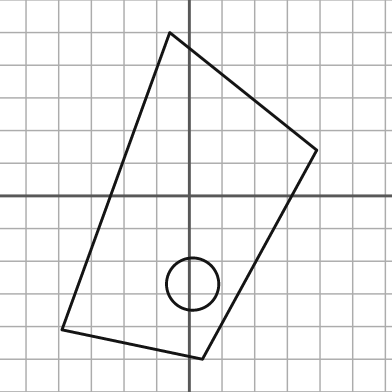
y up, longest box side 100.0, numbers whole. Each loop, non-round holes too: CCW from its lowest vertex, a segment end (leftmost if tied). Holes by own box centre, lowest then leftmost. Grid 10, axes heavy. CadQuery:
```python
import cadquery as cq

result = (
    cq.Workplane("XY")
    .moveTo(4.0, -50.0)
    .lineTo(39.0, 14.0)
    .lineTo(-6.0, 50.0)
    .lineTo(-39.0, -41.0)
    .close()
    .moveTo(1.0, -27.0)
    .circle(8.0)
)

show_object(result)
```